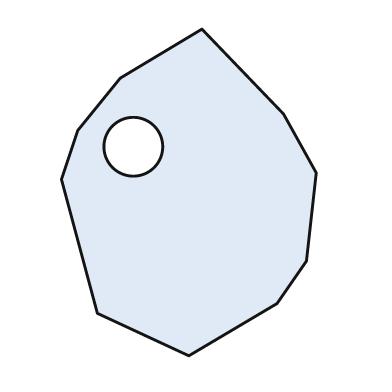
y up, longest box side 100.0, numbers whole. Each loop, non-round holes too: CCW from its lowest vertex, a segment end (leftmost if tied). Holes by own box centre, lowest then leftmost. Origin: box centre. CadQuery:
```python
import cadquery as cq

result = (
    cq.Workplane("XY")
    .moveTo(0.0, -50.0)
    .lineTo(27.0, -34.0)
    .lineTo(36.0, -21.0)
    .lineTo(39.0, 6.0)
    .lineTo(29.0, 24.0)
    .lineTo(4.0, 50.0)
    .lineTo(-21.0, 35.0)
    .lineTo(-34.0, 19.0)
    .lineTo(-39.0, 4.0)
    .lineTo(-28.0, -37.0)
    .close()
    .moveTo(-17.0, 14.0)
    .circle(9.0)
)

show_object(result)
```